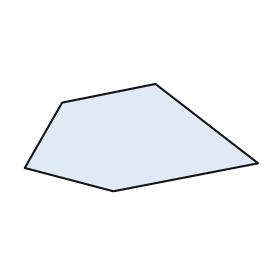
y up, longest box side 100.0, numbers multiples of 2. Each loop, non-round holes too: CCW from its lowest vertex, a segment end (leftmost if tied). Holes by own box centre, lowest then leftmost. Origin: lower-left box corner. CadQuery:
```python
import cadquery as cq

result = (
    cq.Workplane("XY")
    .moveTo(38.0, 0.0)
    .lineTo(100.0, 12.0)
    .lineTo(56.0, 46.0)
    .lineTo(16.0, 38.0)
    .lineTo(0.0, 10.0)
    .close()
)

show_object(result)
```